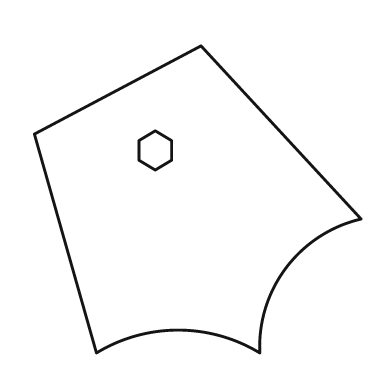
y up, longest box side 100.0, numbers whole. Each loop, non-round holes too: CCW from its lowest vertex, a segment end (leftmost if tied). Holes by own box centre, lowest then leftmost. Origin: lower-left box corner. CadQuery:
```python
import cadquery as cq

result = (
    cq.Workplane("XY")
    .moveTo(19.0, 0.0)
    .threePointArc((44.0, 7.0), (69.0, 0.0))
    .threePointArc((77.0, 26.0), (100.0, 41.0))
    .lineTo(51.0, 94.0)
    .lineTo(0.0, 67.0)
    .close()
    .moveTo(37.0, 56.0)
    .lineTo(42.0, 59.0)
    .lineTo(42.0, 65.0)
    .lineTo(37.0, 68.0)
    .lineTo(32.0, 65.0)
    .lineTo(32.0, 59.0)
    .close()
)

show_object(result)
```